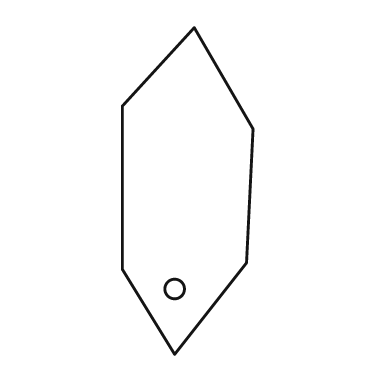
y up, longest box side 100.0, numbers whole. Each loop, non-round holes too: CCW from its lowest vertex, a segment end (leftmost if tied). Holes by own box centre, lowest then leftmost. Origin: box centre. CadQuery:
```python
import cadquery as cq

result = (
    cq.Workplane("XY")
    .moveTo(-4.0, -50.0)
    .lineTo(18.0, -22.0)
    .lineTo(20.0, 19.0)
    .lineTo(2.0, 50.0)
    .lineTo(-20.0, 26.0)
    .lineTo(-20.0, -24.0)
    .close()
    .moveTo(-4.0, -30.0)
    .circle(3.0)
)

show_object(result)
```